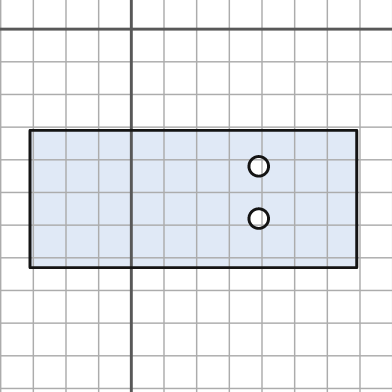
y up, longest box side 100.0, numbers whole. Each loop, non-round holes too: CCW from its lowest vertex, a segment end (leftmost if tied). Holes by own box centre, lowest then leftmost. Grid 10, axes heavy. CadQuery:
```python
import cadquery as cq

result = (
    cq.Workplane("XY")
    .moveTo(-31.0, -73.0)
    .lineTo(69.0, -73.0)
    .lineTo(69.0, -31.0)
    .lineTo(-31.0, -31.0)
    .close()
    .moveTo(39.0, -58.0)
    .circle(3.0)
    .moveTo(39.0, -42.0)
    .circle(3.0)
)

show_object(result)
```